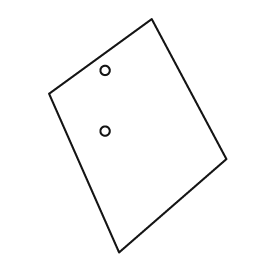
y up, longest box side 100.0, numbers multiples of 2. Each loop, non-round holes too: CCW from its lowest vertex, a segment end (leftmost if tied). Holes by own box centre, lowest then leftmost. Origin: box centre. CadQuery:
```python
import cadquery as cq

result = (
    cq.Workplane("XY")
    .moveTo(-8.0, -50.0)
    .lineTo(38.0, -10.0)
    .lineTo(6.0, 50.0)
    .lineTo(-38.0, 18.0)
    .close()
    .moveTo(-14.0, 2.0)
    .circle(2.0)
    .moveTo(-14.0, 28.0)
    .circle(2.0)
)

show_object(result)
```